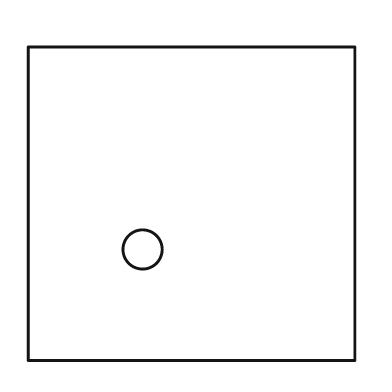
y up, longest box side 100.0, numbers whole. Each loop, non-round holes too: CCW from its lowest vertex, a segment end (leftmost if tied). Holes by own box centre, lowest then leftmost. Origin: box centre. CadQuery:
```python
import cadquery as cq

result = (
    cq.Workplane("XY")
    .moveTo(-50.0, -48.0)
    .lineTo(50.0, -48.0)
    .lineTo(50.0, 48.0)
    .lineTo(-50.0, 48.0)
    .close()
    .moveTo(-15.0, -14.0)
    .circle(6.0)
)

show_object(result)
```